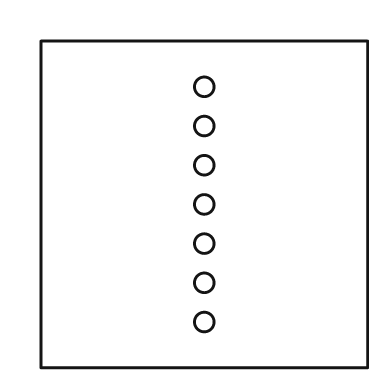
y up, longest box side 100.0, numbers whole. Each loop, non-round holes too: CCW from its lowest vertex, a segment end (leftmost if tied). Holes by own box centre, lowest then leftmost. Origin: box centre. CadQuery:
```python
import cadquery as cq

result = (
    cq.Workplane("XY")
    .moveTo(-50.0, -50.0)
    .lineTo(50.0, -50.0)
    .lineTo(50.0, 50.0)
    .lineTo(-50.0, 50.0)
    .close()
    .moveTo(0.0, -36.0)
    .circle(3.0)
    .moveTo(0.0, -24.0)
    .circle(3.0)
    .moveTo(0.0, -12.0)
    .circle(3.0)
    .moveTo(0.0, 0.0)
    .circle(3.0)
    .moveTo(0.0, 12.0)
    .circle(3.0)
    .moveTo(0.0, 24.0)
    .circle(3.0)
    .moveTo(0.0, 36.0)
    .circle(3.0)
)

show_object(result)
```